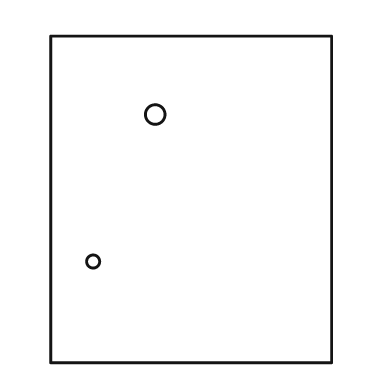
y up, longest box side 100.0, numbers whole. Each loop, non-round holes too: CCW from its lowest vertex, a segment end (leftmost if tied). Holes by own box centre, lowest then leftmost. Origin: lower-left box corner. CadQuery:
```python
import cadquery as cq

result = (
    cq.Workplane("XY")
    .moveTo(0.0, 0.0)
    .lineTo(86.0, 0.0)
    .lineTo(86.0, 100.0)
    .lineTo(0.0, 100.0)
    .close()
    .moveTo(13.0, 31.0)
    .circle(2.0)
    .moveTo(32.0, 76.0)
    .circle(3.0)
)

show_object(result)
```